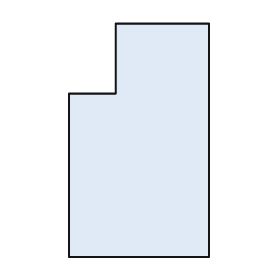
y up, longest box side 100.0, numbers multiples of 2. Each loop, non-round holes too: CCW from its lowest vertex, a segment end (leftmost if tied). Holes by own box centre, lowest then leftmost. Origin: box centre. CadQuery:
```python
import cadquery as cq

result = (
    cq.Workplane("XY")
    .moveTo(-30.0, -50.0)
    .lineTo(30.0, -50.0)
    .lineTo(30.0, 50.0)
    .lineTo(-10.0, 50.0)
    .lineTo(-10.0, 20.0)
    .lineTo(-30.0, 20.0)
    .close()
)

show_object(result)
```